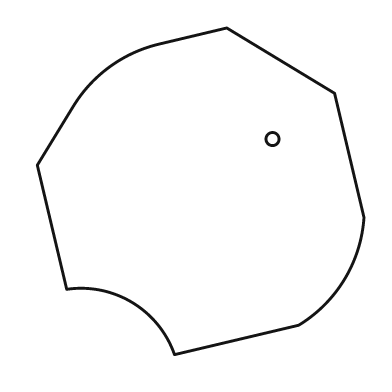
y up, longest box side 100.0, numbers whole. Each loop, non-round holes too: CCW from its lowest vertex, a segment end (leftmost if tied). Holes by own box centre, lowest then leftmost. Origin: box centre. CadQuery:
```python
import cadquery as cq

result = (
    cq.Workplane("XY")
    .moveTo(-8.0, -50.0)
    .lineTo(30.0, -41.0)
    .threePointArc((44.0, -27.0), (50.0, -8.0))
    .lineTo(41.0, 30.0)
    .lineTo(8.0, 50.0)
    .lineTo(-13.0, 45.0)
    .threePointArc((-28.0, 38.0), (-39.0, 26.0))
    .lineTo(-50.0, 8.0)
    .lineTo(-41.0, -30.0)
    .threePointArc((-21.0, -34.0), (-8.0, -50.0))
    .close()
    .moveTo(22.0, 16.0)
    .circle(2.0)
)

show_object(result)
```